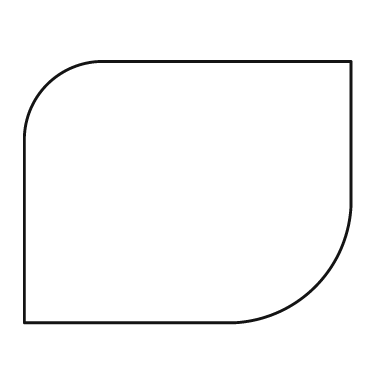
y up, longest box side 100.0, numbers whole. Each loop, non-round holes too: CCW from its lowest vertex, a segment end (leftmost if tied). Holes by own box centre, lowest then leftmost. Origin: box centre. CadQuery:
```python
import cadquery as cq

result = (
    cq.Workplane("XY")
    .moveTo(-50.0, -40.0)
    .lineTo(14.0, -40.0)
    .threePointArc((39.0, -29.0), (50.0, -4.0))
    .lineTo(50.0, 40.0)
    .lineTo(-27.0, 40.0)
    .threePointArc((-43.0, 33.0), (-50.0, 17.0))
    .close()
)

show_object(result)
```